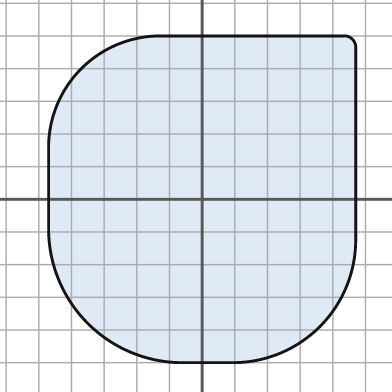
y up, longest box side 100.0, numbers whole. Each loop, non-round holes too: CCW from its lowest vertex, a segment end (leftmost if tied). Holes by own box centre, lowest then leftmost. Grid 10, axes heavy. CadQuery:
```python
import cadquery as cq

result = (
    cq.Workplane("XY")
    .moveTo(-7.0, -50.0)
    .lineTo(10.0, -50.0)
    .threePointArc((36.0, -39.0), (47.0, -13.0))
    .lineTo(47.0, 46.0)
    .threePointArc((46.0, 49.0), (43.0, 50.0))
    .lineTo(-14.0, 50.0)
    .threePointArc((-37.0, 40.0), (-47.0, 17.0))
    .lineTo(-47.0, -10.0)
    .threePointArc((-35.0, -38.0), (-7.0, -50.0))
    .close()
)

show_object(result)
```